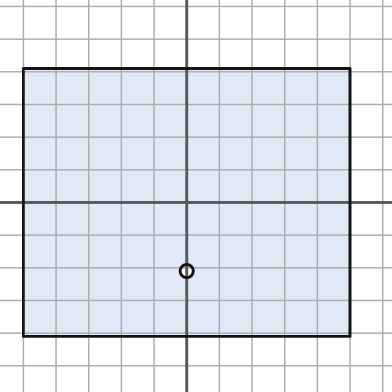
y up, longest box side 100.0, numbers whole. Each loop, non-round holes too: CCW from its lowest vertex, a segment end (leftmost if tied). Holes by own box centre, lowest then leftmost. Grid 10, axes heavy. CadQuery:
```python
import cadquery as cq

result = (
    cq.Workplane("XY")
    .moveTo(-50.0, -41.0)
    .lineTo(50.0, -41.0)
    .lineTo(50.0, 41.0)
    .lineTo(-50.0, 41.0)
    .close()
    .moveTo(0.0, -21.0)
    .circle(2.0)
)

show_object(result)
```